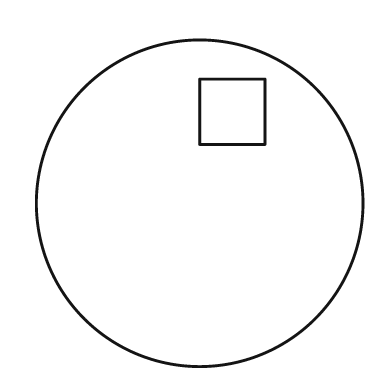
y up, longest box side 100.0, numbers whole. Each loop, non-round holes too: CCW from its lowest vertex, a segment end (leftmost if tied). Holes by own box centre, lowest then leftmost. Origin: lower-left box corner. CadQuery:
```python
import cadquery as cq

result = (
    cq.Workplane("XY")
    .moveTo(50.0, 50.0)
    .circle(50.0)
    .moveTo(50.0, 68.0)
    .lineTo(70.0, 68.0)
    .lineTo(70.0, 88.0)
    .lineTo(50.0, 88.0)
    .close()
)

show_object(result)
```